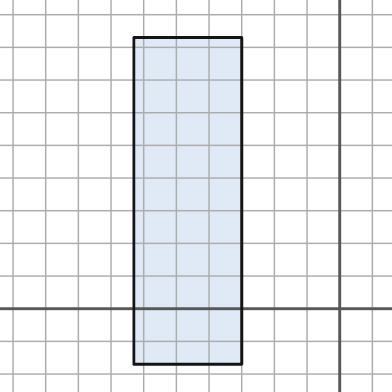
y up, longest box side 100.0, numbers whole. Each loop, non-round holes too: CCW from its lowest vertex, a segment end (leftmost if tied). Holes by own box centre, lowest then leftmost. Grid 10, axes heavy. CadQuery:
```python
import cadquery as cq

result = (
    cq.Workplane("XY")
    .moveTo(-63.0, -17.0)
    .lineTo(-30.0, -17.0)
    .lineTo(-30.0, 83.0)
    .lineTo(-63.0, 83.0)
    .close()
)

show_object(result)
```